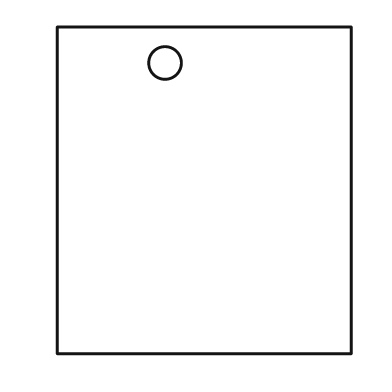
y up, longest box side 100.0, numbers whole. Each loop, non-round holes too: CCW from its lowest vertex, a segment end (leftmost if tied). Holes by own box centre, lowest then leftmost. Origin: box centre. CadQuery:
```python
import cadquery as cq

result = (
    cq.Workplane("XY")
    .moveTo(-45.0, -50.0)
    .lineTo(45.0, -50.0)
    .lineTo(45.0, 50.0)
    .lineTo(-45.0, 50.0)
    .close()
    .moveTo(-12.0, 39.0)
    .circle(5.0)
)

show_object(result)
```